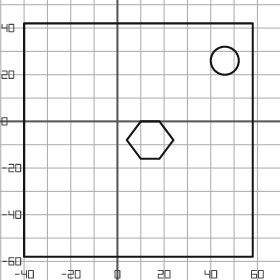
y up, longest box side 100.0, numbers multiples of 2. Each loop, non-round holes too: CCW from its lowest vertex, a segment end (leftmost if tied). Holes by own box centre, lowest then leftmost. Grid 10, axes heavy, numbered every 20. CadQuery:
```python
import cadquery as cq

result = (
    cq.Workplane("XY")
    .moveTo(-40.0, -58.0)
    .lineTo(58.0, -58.0)
    .lineTo(58.0, 42.0)
    .lineTo(-40.0, 42.0)
    .close()
    .moveTo(10.0, -16.0)
    .lineTo(18.0, -16.0)
    .lineTo(24.0, -8.0)
    .lineTo(18.0, 0.0)
    .lineTo(10.0, 0.0)
    .lineTo(4.0, -8.0)
    .close()
    .moveTo(46.0, 26.0)
    .circle(6.0)
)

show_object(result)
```